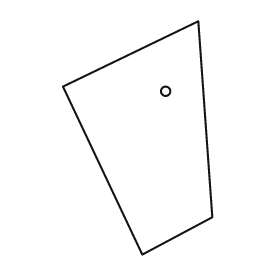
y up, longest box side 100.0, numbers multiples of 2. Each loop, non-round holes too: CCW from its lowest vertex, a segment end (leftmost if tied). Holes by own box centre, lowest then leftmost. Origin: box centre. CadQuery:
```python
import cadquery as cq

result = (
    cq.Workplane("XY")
    .moveTo(2.0, -50.0)
    .lineTo(32.0, -34.0)
    .lineTo(26.0, 50.0)
    .lineTo(-32.0, 22.0)
    .close()
    .moveTo(12.0, 20.0)
    .circle(2.0)
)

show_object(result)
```